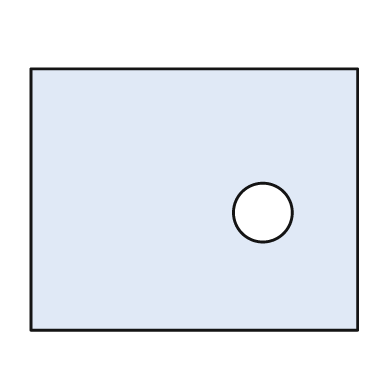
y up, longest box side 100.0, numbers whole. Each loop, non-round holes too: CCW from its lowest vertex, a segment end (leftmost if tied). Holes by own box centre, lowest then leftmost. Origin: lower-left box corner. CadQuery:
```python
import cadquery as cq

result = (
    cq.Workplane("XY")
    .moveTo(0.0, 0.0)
    .lineTo(100.0, 0.0)
    .lineTo(100.0, 80.0)
    .lineTo(0.0, 80.0)
    .close()
    .moveTo(71.0, 36.0)
    .circle(9.0)
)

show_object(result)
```